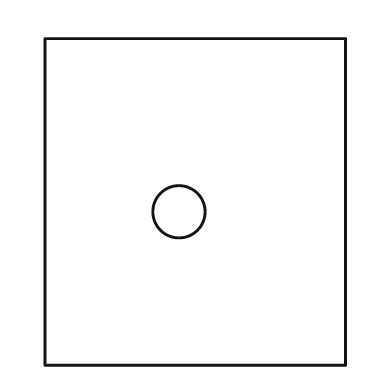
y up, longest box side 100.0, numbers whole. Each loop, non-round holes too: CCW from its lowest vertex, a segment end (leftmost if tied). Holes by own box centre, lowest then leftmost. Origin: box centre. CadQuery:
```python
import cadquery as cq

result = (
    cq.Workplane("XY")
    .moveTo(-46.0, -50.0)
    .lineTo(46.0, -50.0)
    .lineTo(46.0, 50.0)
    .lineTo(-46.0, 50.0)
    .close()
    .moveTo(-5.0, -3.0)
    .circle(8.0)
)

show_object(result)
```